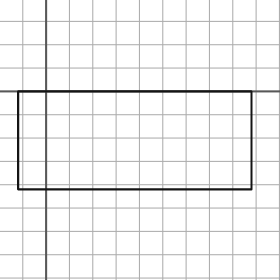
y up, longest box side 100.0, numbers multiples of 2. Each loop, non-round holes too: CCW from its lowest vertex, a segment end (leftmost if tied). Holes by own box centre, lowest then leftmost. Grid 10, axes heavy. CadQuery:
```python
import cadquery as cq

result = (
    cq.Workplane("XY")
    .moveTo(-12.0, -42.0)
    .lineTo(88.0, -42.0)
    .lineTo(88.0, 0.0)
    .lineTo(-12.0, 0.0)
    .close()
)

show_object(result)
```